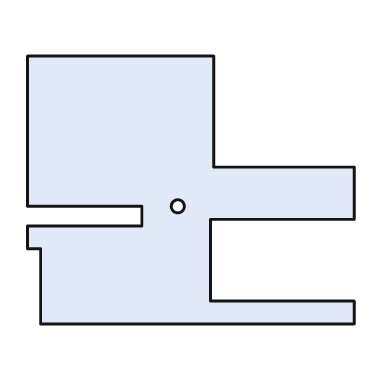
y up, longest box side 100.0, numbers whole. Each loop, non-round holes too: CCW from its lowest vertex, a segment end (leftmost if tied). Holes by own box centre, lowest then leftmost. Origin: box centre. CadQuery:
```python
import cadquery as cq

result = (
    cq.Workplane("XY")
    .moveTo(-46.0, -41.0)
    .lineTo(50.0, -41.0)
    .lineTo(50.0, -34.0)
    .lineTo(6.0, -34.0)
    .lineTo(6.0, -9.0)
    .lineTo(50.0, -9.0)
    .lineTo(50.0, 7.0)
    .lineTo(7.0, 7.0)
    .lineTo(7.0, 41.0)
    .lineTo(-50.0, 41.0)
    .lineTo(-50.0, -5.0)
    .lineTo(-15.0, -5.0)
    .lineTo(-15.0, -11.0)
    .lineTo(-50.0, -11.0)
    .lineTo(-50.0, -18.0)
    .lineTo(-46.0, -18.0)
    .close()
    .moveTo(-4.0, -5.0)
    .circle(2.0)
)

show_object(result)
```